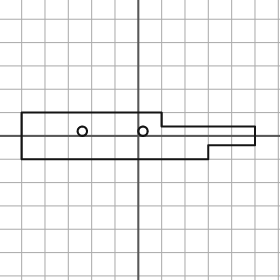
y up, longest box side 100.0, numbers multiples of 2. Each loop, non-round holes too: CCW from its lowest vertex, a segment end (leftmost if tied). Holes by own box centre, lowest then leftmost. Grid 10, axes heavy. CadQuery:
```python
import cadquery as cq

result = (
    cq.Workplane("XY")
    .moveTo(-50.0, -10.0)
    .lineTo(30.0, -10.0)
    .lineTo(30.0, -4.0)
    .lineTo(50.0, -4.0)
    .lineTo(50.0, 4.0)
    .lineTo(10.0, 4.0)
    .lineTo(10.0, 10.0)
    .lineTo(-50.0, 10.0)
    .close()
    .moveTo(-24.0, 2.0)
    .circle(2.0)
    .moveTo(2.0, 2.0)
    .circle(2.0)
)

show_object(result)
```